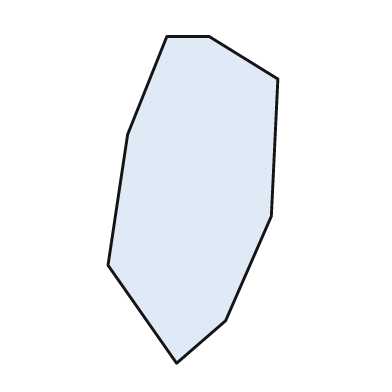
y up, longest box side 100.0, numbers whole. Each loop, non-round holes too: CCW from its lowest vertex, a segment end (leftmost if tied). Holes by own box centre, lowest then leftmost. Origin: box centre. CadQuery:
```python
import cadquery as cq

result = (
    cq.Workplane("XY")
    .moveTo(-5.0, -50.0)
    .lineTo(10.0, -37.0)
    .lineTo(24.0, -5.0)
    .lineTo(26.0, 37.0)
    .lineTo(5.0, 50.0)
    .lineTo(-8.0, 50.0)
    .lineTo(-20.0, 20.0)
    .lineTo(-26.0, -20.0)
    .close()
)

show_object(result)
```